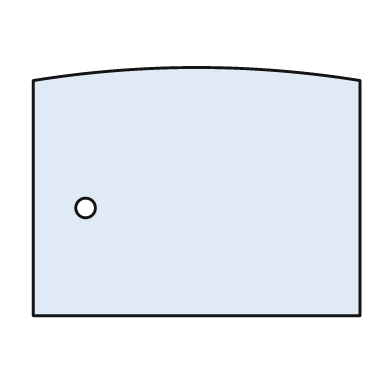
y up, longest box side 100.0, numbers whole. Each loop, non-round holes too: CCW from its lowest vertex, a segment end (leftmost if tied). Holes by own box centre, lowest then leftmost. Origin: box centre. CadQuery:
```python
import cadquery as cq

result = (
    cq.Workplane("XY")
    .moveTo(-50.0, -38.0)
    .lineTo(50.0, -38.0)
    .lineTo(50.0, 34.0)
    .threePointArc((0.0, 38.0), (-50.0, 34.0))
    .close()
    .moveTo(-34.0, -5.0)
    .circle(3.0)
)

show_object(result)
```